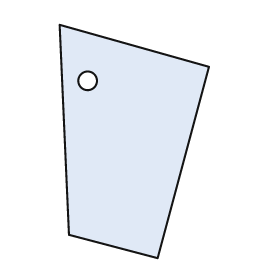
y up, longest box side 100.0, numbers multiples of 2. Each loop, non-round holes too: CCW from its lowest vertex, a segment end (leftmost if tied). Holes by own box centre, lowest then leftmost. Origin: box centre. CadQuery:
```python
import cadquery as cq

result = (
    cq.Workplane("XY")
    .moveTo(10.0, -50.0)
    .lineTo(32.0, 32.0)
    .lineTo(-32.0, 50.0)
    .lineTo(-28.0, -40.0)
    .close()
    .moveTo(-20.0, 26.0)
    .circle(4.0)
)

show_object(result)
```